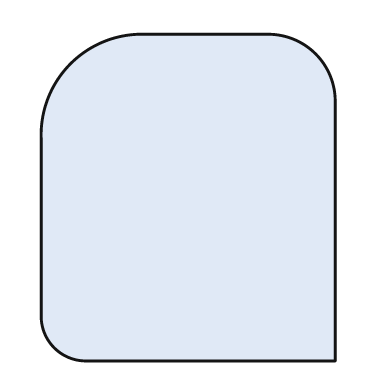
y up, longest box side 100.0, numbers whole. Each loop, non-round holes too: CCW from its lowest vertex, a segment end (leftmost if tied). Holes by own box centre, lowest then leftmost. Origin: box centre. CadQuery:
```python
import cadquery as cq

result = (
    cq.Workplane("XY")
    .moveTo(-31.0, -50.0)
    .lineTo(45.0, -50.0)
    .lineTo(45.0, 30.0)
    .threePointArc((39.0, 44.0), (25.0, 50.0))
    .lineTo(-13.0, 50.0)
    .threePointArc((-36.0, 41.0), (-45.0, 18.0))
    .lineTo(-45.0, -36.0)
    .threePointArc((-41.0, -46.0), (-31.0, -50.0))
    .close()
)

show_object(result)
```